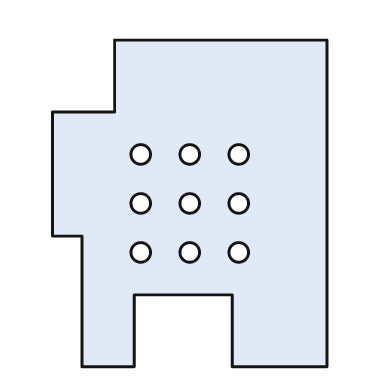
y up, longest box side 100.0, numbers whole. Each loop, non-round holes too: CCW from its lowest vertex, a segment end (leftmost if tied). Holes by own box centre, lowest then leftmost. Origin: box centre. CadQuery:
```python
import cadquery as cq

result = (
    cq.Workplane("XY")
    .moveTo(-33.0, -50.0)
    .lineTo(-17.0, -50.0)
    .lineTo(-17.0, -28.0)
    .lineTo(13.0, -28.0)
    .lineTo(13.0, -50.0)
    .lineTo(42.0, -50.0)
    .lineTo(42.0, 50.0)
    .lineTo(-23.0, 50.0)
    .lineTo(-23.0, 28.0)
    .lineTo(-42.0, 28.0)
    .lineTo(-42.0, -10.0)
    .lineTo(-33.0, -10.0)
    .close()
    .moveTo(-15.0, -15.0)
    .circle(3.0)
    .moveTo(0.0, -15.0)
    .circle(3.0)
    .moveTo(15.0, -15.0)
    .circle(3.0)
    .moveTo(-15.0, 0.0)
    .circle(3.0)
    .moveTo(0.0, 0.0)
    .circle(3.0)
    .moveTo(15.0, 0.0)
    .circle(3.0)
    .moveTo(-15.0, 15.0)
    .circle(3.0)
    .moveTo(0.0, 15.0)
    .circle(3.0)
    .moveTo(15.0, 15.0)
    .circle(3.0)
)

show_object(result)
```